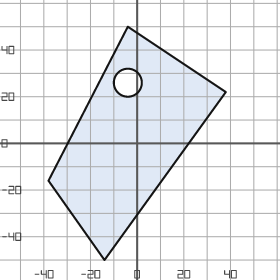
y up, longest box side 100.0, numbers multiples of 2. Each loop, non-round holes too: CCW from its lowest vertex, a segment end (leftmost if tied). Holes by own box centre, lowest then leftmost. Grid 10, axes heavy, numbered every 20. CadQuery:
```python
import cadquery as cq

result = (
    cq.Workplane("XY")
    .moveTo(-14.0, -50.0)
    .lineTo(38.0, 22.0)
    .lineTo(-4.0, 50.0)
    .lineTo(-38.0, -16.0)
    .close()
    .moveTo(-4.0, 26.0)
    .circle(6.0)
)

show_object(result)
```